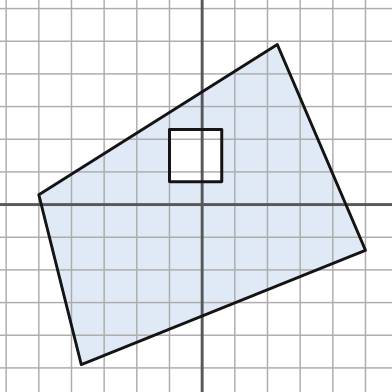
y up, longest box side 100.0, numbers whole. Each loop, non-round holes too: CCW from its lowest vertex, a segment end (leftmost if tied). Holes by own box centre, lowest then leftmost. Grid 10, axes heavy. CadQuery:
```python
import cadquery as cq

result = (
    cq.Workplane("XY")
    .moveTo(-37.0, -49.0)
    .lineTo(50.0, -14.0)
    .lineTo(23.0, 49.0)
    .lineTo(-50.0, 3.0)
    .close()
    .moveTo(-10.0, 7.0)
    .lineTo(6.0, 7.0)
    .lineTo(6.0, 23.0)
    .lineTo(-10.0, 23.0)
    .close()
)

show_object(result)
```